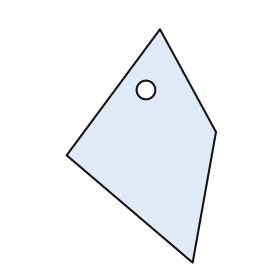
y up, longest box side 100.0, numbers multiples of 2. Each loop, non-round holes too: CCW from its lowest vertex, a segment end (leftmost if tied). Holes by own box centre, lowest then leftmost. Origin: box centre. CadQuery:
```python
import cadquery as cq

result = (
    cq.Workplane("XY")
    .moveTo(22.0, -50.0)
    .lineTo(32.0, 6.0)
    .lineTo(8.0, 50.0)
    .lineTo(-32.0, -4.0)
    .close()
    .moveTo(2.0, 24.0)
    .circle(4.0)
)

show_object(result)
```